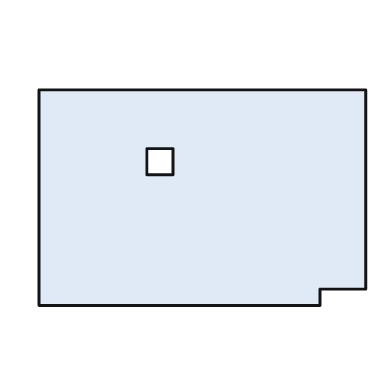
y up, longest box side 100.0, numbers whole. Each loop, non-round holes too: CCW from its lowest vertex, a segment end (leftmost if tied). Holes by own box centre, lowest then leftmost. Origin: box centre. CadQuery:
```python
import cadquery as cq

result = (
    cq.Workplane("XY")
    .moveTo(-50.0, -33.0)
    .lineTo(36.0, -33.0)
    .lineTo(36.0, -28.0)
    .lineTo(50.0, -28.0)
    .lineTo(50.0, 33.0)
    .lineTo(-50.0, 33.0)
    .close()
    .moveTo(-17.0, 7.0)
    .lineTo(-9.0, 7.0)
    .lineTo(-9.0, 15.0)
    .lineTo(-17.0, 15.0)
    .close()
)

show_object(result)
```